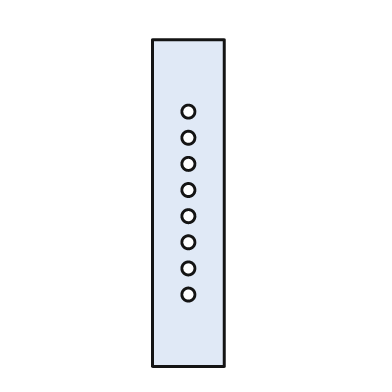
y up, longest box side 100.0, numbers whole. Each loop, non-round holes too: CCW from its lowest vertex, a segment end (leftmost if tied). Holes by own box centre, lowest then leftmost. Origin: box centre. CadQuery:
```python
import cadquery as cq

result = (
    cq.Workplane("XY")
    .moveTo(-11.0, -50.0)
    .lineTo(11.0, -50.0)
    .lineTo(11.0, 50.0)
    .lineTo(-11.0, 50.0)
    .close()
    .moveTo(0.0, -28.0)
    .circle(2.0)
    .moveTo(0.0, -20.0)
    .circle(2.0)
    .moveTo(0.0, -12.0)
    .circle(2.0)
    .moveTo(0.0, -4.0)
    .circle(2.0)
    .moveTo(0.0, 4.0)
    .circle(2.0)
    .moveTo(0.0, 12.0)
    .circle(2.0)
    .moveTo(0.0, 20.0)
    .circle(2.0)
    .moveTo(0.0, 28.0)
    .circle(2.0)
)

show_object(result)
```